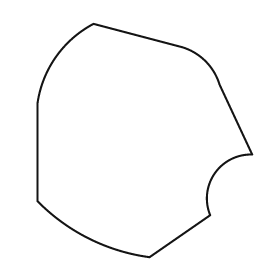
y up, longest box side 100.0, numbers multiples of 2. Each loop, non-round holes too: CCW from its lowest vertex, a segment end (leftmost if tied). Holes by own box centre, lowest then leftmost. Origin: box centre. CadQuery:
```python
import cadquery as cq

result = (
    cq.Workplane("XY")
    .moveTo(2.0, -50.0)
    .lineTo(28.0, -32.0)
    .threePointArc((30.0, -14.0), (46.0, -6.0))
    .lineTo(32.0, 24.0)
    .threePointArc((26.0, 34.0), (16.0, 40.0))
    .lineTo(-22.0, 50.0)
    .threePointArc((-38.0, 36.0), (-46.0, 16.0))
    .lineTo(-46.0, -26.0)
    .threePointArc((-24.0, -42.0), (2.0, -50.0))
    .close()
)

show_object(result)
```